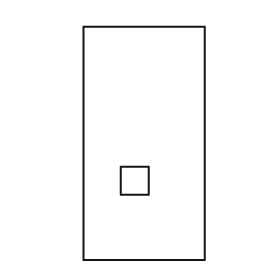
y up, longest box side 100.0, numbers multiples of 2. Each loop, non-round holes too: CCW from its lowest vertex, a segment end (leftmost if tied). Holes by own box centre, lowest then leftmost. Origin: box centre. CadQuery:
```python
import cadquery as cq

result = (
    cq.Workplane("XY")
    .moveTo(-26.0, -50.0)
    .lineTo(26.0, -50.0)
    .lineTo(26.0, 50.0)
    .lineTo(-26.0, 50.0)
    .close()
    .moveTo(-10.0, -22.0)
    .lineTo(2.0, -22.0)
    .lineTo(2.0, -10.0)
    .lineTo(-10.0, -10.0)
    .close()
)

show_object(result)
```